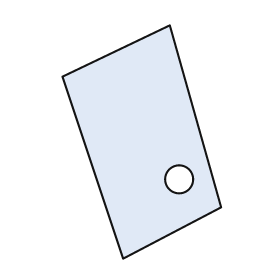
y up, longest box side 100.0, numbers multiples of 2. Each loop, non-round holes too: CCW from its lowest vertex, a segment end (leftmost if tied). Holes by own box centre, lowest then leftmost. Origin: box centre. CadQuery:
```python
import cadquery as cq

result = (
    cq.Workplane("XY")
    .moveTo(-8.0, -50.0)
    .lineTo(34.0, -28.0)
    .lineTo(12.0, 50.0)
    .lineTo(-34.0, 28.0)
    .close()
    .moveTo(16.0, -16.0)
    .circle(6.0)
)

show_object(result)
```